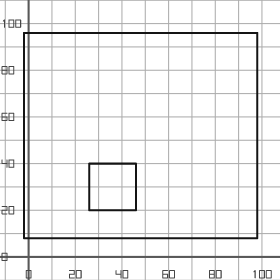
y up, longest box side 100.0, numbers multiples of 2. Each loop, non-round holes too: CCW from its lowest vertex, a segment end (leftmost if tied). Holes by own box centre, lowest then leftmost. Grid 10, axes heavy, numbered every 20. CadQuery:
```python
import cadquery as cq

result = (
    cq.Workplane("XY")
    .moveTo(-2.0, 8.0)
    .lineTo(98.0, 8.0)
    .lineTo(98.0, 96.0)
    .lineTo(-2.0, 96.0)
    .close()
    .moveTo(26.0, 20.0)
    .lineTo(46.0, 20.0)
    .lineTo(46.0, 40.0)
    .lineTo(26.0, 40.0)
    .close()
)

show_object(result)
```